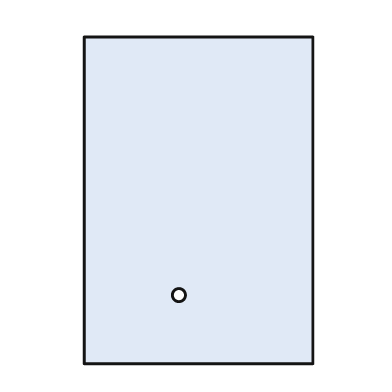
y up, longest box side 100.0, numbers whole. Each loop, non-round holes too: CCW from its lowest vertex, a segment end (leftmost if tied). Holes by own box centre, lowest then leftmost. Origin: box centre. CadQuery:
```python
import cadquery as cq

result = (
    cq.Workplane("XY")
    .moveTo(-35.0, -50.0)
    .lineTo(35.0, -50.0)
    .lineTo(35.0, 50.0)
    .lineTo(-35.0, 50.0)
    .close()
    .moveTo(-6.0, -29.0)
    .circle(2.0)
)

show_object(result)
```